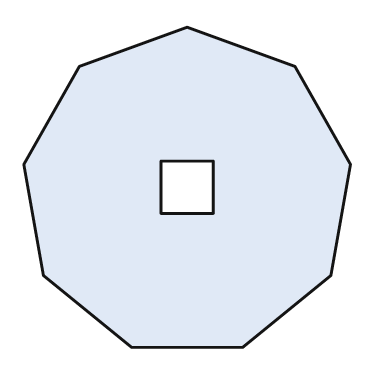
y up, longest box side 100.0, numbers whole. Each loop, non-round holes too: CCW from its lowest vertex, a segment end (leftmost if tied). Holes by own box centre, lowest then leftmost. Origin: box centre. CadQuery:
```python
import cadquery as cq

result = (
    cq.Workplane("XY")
    .moveTo(-17.0, -49.0)
    .lineTo(17.0, -49.0)
    .lineTo(44.0, -27.0)
    .lineTo(50.0, 7.0)
    .lineTo(33.0, 37.0)
    .lineTo(0.0, 49.0)
    .lineTo(-33.0, 37.0)
    .lineTo(-50.0, 7.0)
    .lineTo(-44.0, -27.0)
    .close()
    .moveTo(-8.0, -8.0)
    .lineTo(8.0, -8.0)
    .lineTo(8.0, 8.0)
    .lineTo(-8.0, 8.0)
    .close()
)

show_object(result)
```